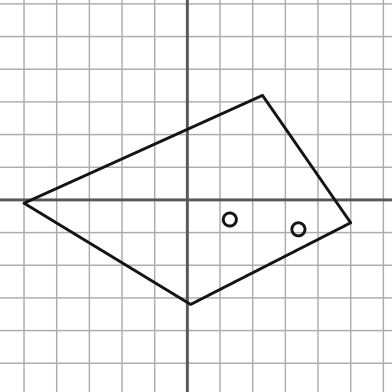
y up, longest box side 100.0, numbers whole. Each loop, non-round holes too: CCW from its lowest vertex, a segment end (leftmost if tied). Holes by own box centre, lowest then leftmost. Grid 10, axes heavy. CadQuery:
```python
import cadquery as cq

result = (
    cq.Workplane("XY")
    .moveTo(1.0, -32.0)
    .lineTo(50.0, -7.0)
    .lineTo(23.0, 32.0)
    .lineTo(-50.0, -1.0)
    .close()
    .moveTo(34.0, -9.0)
    .circle(2.0)
    .moveTo(13.0, -6.0)
    .circle(2.0)
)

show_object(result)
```